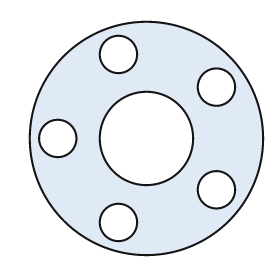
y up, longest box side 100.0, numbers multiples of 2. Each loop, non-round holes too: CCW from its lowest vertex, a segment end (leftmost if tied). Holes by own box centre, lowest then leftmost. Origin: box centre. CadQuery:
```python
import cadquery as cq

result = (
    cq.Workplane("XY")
    .moveTo(0.0, 0.0)
    .circle(50.0)
    .moveTo(-12.0, -36.0)
    .circle(8.0)
    .moveTo(30.0, -22.0)
    .circle(8.0)
    .moveTo(-38.0, 0.0)
    .circle(8.0)
    .moveTo(0.0, 0.0)
    .circle(20.0)
    .moveTo(30.0, 22.0)
    .circle(8.0)
    .moveTo(-12.0, 36.0)
    .circle(8.0)
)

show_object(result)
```